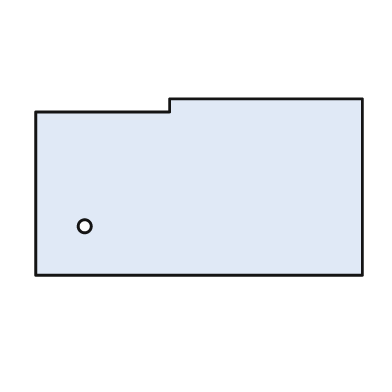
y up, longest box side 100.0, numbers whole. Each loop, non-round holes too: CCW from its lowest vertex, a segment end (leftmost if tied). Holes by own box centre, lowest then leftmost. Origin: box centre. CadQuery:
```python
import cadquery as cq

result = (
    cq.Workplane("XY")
    .moveTo(-50.0, -27.0)
    .lineTo(50.0, -27.0)
    .lineTo(50.0, 27.0)
    .lineTo(-9.0, 27.0)
    .lineTo(-9.0, 23.0)
    .lineTo(-50.0, 23.0)
    .close()
    .moveTo(-35.0, -12.0)
    .circle(2.0)
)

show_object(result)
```